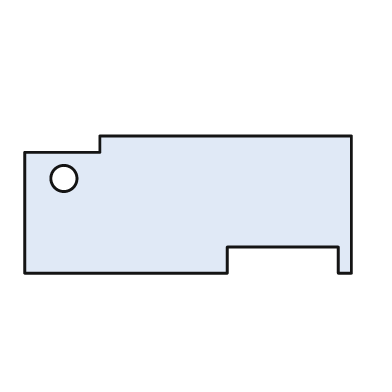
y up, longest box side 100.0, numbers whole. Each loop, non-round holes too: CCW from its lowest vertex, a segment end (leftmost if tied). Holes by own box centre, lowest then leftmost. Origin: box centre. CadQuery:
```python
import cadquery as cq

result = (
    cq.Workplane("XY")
    .moveTo(-50.0, -21.0)
    .lineTo(12.0, -21.0)
    .lineTo(12.0, -13.0)
    .lineTo(46.0, -13.0)
    .lineTo(46.0, -21.0)
    .lineTo(50.0, -21.0)
    .lineTo(50.0, 21.0)
    .lineTo(-27.0, 21.0)
    .lineTo(-27.0, 16.0)
    .lineTo(-50.0, 16.0)
    .close()
    .moveTo(-38.0, 8.0)
    .circle(4.0)
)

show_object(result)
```